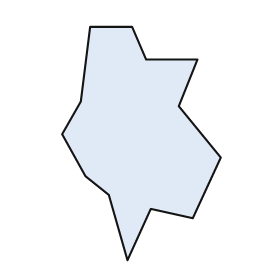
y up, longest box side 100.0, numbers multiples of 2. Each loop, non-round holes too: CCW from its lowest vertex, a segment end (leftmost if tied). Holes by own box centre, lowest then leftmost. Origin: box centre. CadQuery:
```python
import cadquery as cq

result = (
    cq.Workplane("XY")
    .moveTo(-6.0, -50.0)
    .lineTo(4.0, -28.0)
    .lineTo(22.0, -32.0)
    .lineTo(34.0, -6.0)
    .lineTo(16.0, 16.0)
    .lineTo(24.0, 36.0)
    .lineTo(2.0, 36.0)
    .lineTo(-4.0, 50.0)
    .lineTo(-22.0, 50.0)
    .lineTo(-26.0, 18.0)
    .lineTo(-34.0, 4.0)
    .lineTo(-24.0, -14.0)
    .lineTo(-14.0, -22.0)
    .close()
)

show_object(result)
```